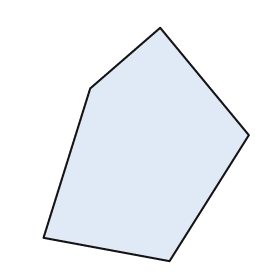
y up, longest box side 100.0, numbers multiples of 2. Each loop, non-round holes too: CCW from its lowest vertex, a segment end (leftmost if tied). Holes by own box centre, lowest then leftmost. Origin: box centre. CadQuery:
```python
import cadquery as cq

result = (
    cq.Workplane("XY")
    .moveTo(10.0, -50.0)
    .lineTo(44.0, 4.0)
    .lineTo(6.0, 50.0)
    .lineTo(-24.0, 24.0)
    .lineTo(-44.0, -40.0)
    .close()
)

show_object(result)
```